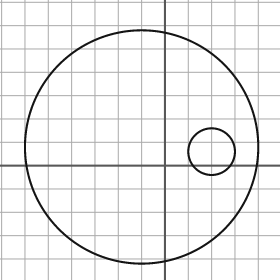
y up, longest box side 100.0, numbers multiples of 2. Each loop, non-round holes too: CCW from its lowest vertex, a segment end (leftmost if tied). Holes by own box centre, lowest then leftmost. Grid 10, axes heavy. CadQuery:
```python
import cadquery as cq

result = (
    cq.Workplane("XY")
    .moveTo(-10.0, 8.0)
    .circle(50.0)
    .moveTo(20.0, 6.0)
    .circle(10.0)
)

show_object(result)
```